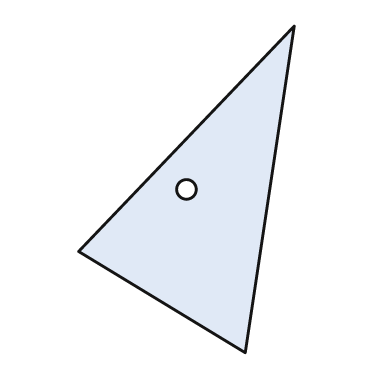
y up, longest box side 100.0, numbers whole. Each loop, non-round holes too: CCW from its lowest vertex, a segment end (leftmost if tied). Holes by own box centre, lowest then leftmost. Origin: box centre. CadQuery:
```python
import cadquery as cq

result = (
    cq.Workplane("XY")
    .moveTo(18.0, -50.0)
    .lineTo(33.0, 50.0)
    .lineTo(-33.0, -19.0)
    .close()
    .moveTo(0.0, 0.0)
    .circle(3.0)
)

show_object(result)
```